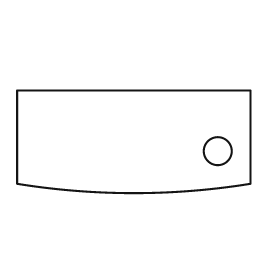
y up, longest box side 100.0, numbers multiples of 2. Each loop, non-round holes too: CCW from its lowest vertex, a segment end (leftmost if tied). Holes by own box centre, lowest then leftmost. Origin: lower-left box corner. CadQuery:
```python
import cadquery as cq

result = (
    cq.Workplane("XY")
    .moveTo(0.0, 4.0)
    .threePointArc((50.0, 0.0), (100.0, 4.0))
    .lineTo(100.0, 44.0)
    .lineTo(0.0, 44.0)
    .close()
    .moveTo(86.0, 18.0)
    .circle(6.0)
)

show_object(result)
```